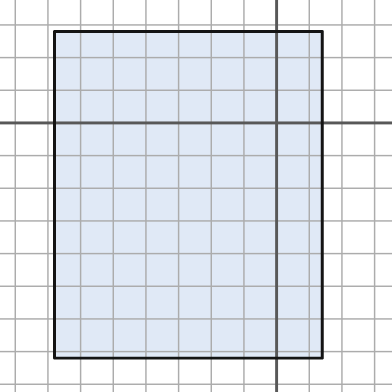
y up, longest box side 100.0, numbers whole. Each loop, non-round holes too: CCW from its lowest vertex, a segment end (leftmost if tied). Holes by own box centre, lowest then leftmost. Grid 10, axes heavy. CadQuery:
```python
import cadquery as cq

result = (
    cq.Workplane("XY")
    .moveTo(-68.0, -72.0)
    .lineTo(14.0, -72.0)
    .lineTo(14.0, 28.0)
    .lineTo(-68.0, 28.0)
    .close()
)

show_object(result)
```